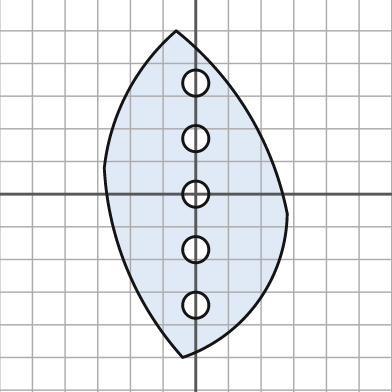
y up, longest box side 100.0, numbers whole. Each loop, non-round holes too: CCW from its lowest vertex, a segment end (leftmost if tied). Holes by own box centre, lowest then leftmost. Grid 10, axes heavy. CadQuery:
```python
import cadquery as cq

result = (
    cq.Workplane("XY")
    .moveTo(-4.0, -50.0)
    .threePointArc((19.0, -33.0), (28.0, -6.0))
    .threePointArc((16.0, 25.0), (-6.0, 50.0))
    .threePointArc((-21.0, 31.0), (-28.0, 8.0))
    .threePointArc((-21.0, -23.0), (-4.0, -50.0))
    .close()
    .moveTo(0.0, -34.0)
    .circle(4.0)
    .moveTo(0.0, -17.0)
    .circle(4.0)
    .moveTo(0.0, 0.0)
    .circle(4.0)
    .moveTo(0.0, 17.0)
    .circle(4.0)
    .moveTo(0.0, 34.0)
    .circle(4.0)
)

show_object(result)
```